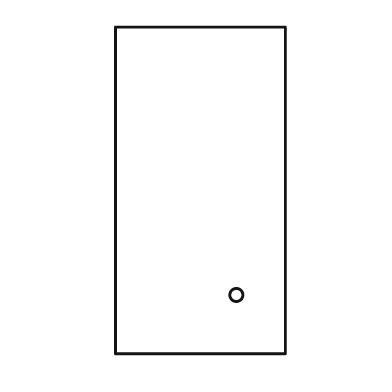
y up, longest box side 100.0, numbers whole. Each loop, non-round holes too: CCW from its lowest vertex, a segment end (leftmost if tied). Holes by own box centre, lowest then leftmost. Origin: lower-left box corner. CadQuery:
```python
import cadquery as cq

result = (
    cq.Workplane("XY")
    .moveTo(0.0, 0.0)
    .lineTo(52.0, 0.0)
    .lineTo(52.0, 100.0)
    .lineTo(0.0, 100.0)
    .close()
    .moveTo(37.0, 18.0)
    .circle(2.0)
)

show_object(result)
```